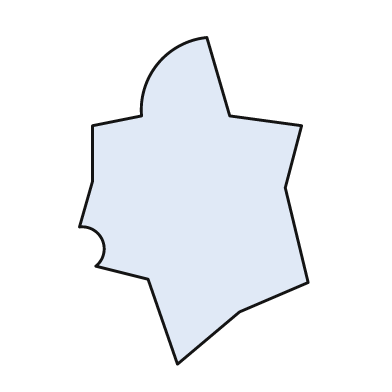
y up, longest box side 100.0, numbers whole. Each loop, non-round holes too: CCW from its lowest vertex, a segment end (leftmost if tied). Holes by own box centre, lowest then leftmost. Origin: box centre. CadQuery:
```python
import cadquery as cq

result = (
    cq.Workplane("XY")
    .moveTo(-5.0, -50.0)
    .lineTo(14.0, -34.0)
    .lineTo(35.0, -25.0)
    .lineTo(28.0, 4.0)
    .lineTo(33.0, 23.0)
    .lineTo(11.0, 26.0)
    .lineTo(4.0, 50.0)
    .threePointArc((-11.0, 42.0), (-16.0, 26.0))
    .lineTo(-31.0, 23.0)
    .lineTo(-31.0, 6.0)
    .lineTo(-35.0, -8.0)
    .threePointArc((-28.0, -12.0), (-30.0, -20.0))
    .lineTo(-14.0, -24.0)
    .close()
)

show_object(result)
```